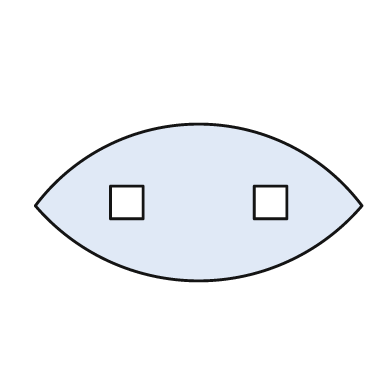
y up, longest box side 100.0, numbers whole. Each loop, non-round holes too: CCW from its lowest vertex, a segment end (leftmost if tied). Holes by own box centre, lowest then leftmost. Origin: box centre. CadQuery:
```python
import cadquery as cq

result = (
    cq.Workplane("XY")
    .moveTo(-50.0, -1.0)
    .threePointArc((0.0, -24.0), (50.0, -1.0))
    .threePointArc((0.0, 24.0), (-50.0, -1.0))
    .close()
    .moveTo(-27.0, -5.0)
    .lineTo(-17.0, -5.0)
    .lineTo(-17.0, 5.0)
    .lineTo(-27.0, 5.0)
    .close()
    .moveTo(17.0, -5.0)
    .lineTo(27.0, -5.0)
    .lineTo(27.0, 5.0)
    .lineTo(17.0, 5.0)
    .close()
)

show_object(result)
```